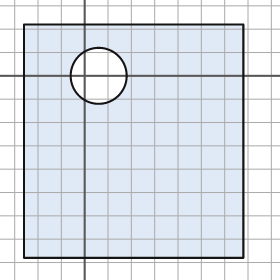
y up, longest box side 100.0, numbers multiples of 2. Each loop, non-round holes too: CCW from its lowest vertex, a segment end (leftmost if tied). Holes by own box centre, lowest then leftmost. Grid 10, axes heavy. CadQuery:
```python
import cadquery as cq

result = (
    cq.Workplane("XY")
    .moveTo(-26.0, -78.0)
    .lineTo(68.0, -78.0)
    .lineTo(68.0, 22.0)
    .lineTo(-26.0, 22.0)
    .close()
    .moveTo(6.0, 0.0)
    .circle(12.0)
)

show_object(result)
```